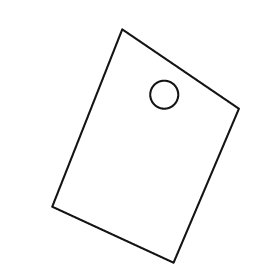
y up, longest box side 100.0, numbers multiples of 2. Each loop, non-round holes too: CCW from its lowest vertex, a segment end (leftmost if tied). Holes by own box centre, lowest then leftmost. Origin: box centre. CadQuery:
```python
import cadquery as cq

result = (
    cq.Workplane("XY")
    .moveTo(12.0, -50.0)
    .lineTo(40.0, 16.0)
    .lineTo(-10.0, 50.0)
    .lineTo(-40.0, -26.0)
    .close()
    .moveTo(8.0, 22.0)
    .circle(6.0)
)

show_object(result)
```